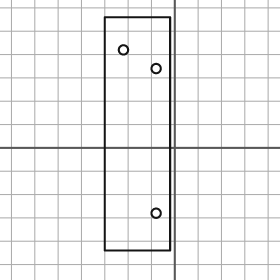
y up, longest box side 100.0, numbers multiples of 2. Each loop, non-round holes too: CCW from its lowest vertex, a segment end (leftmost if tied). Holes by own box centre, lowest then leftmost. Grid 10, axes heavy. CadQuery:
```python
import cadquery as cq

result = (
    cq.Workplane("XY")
    .moveTo(-30.0, -44.0)
    .lineTo(-2.0, -44.0)
    .lineTo(-2.0, 56.0)
    .lineTo(-30.0, 56.0)
    .close()
    .moveTo(-8.0, -28.0)
    .circle(2.0)
    .moveTo(-8.0, 34.0)
    .circle(2.0)
    .moveTo(-22.0, 42.0)
    .circle(2.0)
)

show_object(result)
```